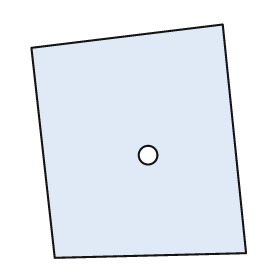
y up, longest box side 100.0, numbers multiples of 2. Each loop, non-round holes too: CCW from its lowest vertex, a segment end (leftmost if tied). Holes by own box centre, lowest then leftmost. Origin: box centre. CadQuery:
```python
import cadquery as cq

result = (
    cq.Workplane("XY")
    .moveTo(-36.0, -50.0)
    .lineTo(46.0, -48.0)
    .lineTo(36.0, 50.0)
    .lineTo(-46.0, 40.0)
    .close()
    .moveTo(4.0, -6.0)
    .circle(4.0)
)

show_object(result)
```